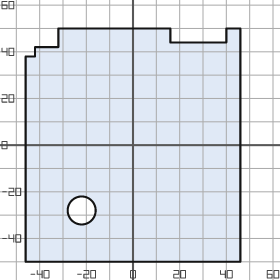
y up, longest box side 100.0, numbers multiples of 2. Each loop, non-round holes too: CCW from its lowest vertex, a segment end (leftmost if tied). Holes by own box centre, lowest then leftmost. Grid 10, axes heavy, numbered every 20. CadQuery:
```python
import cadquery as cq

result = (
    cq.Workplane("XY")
    .moveTo(-46.0, -50.0)
    .lineTo(46.0, -50.0)
    .lineTo(46.0, 50.0)
    .lineTo(40.0, 50.0)
    .lineTo(40.0, 44.0)
    .lineTo(16.0, 44.0)
    .lineTo(16.0, 50.0)
    .lineTo(-32.0, 50.0)
    .lineTo(-32.0, 42.0)
    .lineTo(-42.0, 42.0)
    .lineTo(-42.0, 38.0)
    .lineTo(-46.0, 38.0)
    .close()
    .moveTo(-22.0, -28.0)
    .circle(6.0)
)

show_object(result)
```